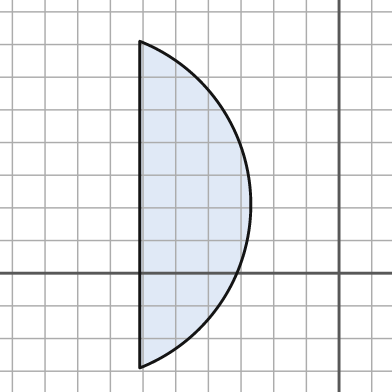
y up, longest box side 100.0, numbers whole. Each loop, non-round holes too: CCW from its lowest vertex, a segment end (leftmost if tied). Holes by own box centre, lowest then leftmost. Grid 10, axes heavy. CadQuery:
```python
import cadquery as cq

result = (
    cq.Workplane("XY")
    .moveTo(-61.0, -29.0)
    .threePointArc((-27.0, 21.0), (-61.0, 71.0))
    .close()
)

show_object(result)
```